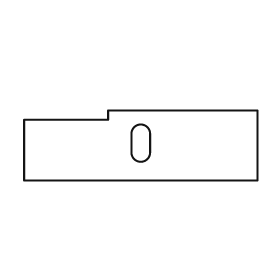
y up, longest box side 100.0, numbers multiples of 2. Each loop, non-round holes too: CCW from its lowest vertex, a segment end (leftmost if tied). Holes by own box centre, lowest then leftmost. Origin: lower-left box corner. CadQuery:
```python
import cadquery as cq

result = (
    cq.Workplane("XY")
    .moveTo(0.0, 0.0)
    .lineTo(100.0, 0.0)
    .lineTo(100.0, 30.0)
    .lineTo(36.0, 30.0)
    .lineTo(36.0, 26.0)
    .lineTo(0.0, 26.0)
    .close()
    .moveTo(46.0, 12.0)
    .threePointArc((50.0, 8.0), (54.0, 12.0))
    .lineTo(54.0, 20.0)
    .threePointArc((50.0, 24.0), (46.0, 20.0))
    .close()
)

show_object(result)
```